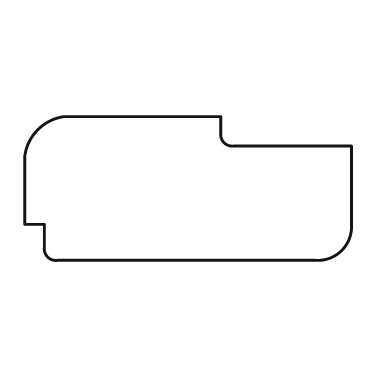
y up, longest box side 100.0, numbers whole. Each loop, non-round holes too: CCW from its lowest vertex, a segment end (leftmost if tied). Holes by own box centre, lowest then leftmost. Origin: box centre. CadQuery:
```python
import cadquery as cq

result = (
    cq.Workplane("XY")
    .moveTo(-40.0, -22.0)
    .lineTo(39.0, -22.0)
    .threePointArc((47.0, -19.0), (50.0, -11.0))
    .lineTo(50.0, 13.0)
    .lineTo(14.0, 13.0)
    .threePointArc((11.0, 14.0), (10.0, 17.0))
    .lineTo(10.0, 22.0)
    .lineTo(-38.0, 22.0)
    .threePointArc((-46.0, 18.0), (-50.0, 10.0))
    .lineTo(-50.0, -11.0)
    .lineTo(-44.0, -11.0)
    .lineTo(-44.0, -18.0)
    .threePointArc((-43.0, -21.0), (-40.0, -22.0))
    .close()
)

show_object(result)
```